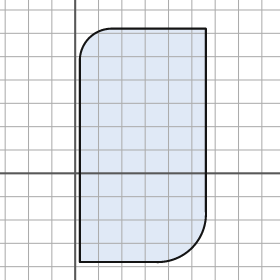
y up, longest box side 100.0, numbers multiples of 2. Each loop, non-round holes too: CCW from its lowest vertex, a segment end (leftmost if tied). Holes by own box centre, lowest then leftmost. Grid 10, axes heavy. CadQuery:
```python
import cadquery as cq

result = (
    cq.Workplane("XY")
    .moveTo(2.0, -38.0)
    .lineTo(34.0, -38.0)
    .threePointArc((50.0, -32.0), (56.0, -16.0))
    .lineTo(56.0, 62.0)
    .lineTo(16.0, 62.0)
    .threePointArc((6.0, 58.0), (2.0, 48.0))
    .close()
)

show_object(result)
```